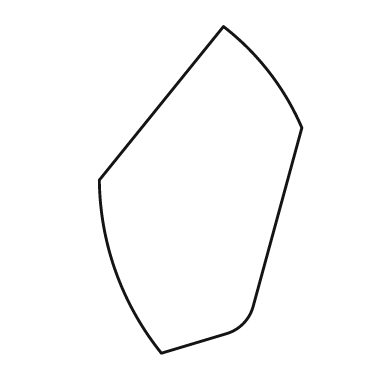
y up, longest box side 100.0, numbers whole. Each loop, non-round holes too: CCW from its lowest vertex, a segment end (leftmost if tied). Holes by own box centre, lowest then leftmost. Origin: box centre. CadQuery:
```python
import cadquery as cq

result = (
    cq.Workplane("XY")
    .moveTo(-12.0, -50.0)
    .lineTo(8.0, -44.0)
    .threePointArc((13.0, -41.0), (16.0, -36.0))
    .lineTo(31.0, 19.0)
    .threePointArc((21.0, 36.0), (7.0, 50.0))
    .lineTo(-31.0, 3.0)
    .threePointArc((-26.0, -25.0), (-12.0, -50.0))
    .close()
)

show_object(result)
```